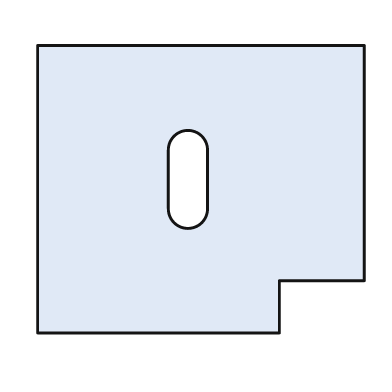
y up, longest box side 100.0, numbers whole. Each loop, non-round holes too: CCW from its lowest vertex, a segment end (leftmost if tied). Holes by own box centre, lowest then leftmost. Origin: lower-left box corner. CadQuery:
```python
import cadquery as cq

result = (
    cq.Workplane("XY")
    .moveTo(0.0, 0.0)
    .lineTo(74.0, 0.0)
    .lineTo(74.0, 16.0)
    .lineTo(100.0, 16.0)
    .lineTo(100.0, 88.0)
    .lineTo(0.0, 88.0)
    .close()
    .moveTo(40.0, 38.0)
    .threePointArc((46.0, 32.0), (52.0, 38.0))
    .lineTo(52.0, 56.0)
    .threePointArc((46.0, 62.0), (40.0, 56.0))
    .close()
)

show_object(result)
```